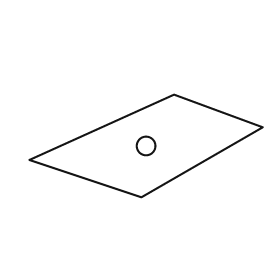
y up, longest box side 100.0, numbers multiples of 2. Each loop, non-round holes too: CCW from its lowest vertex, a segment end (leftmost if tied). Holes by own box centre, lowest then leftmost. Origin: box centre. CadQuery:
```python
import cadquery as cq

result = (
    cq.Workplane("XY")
    .moveTo(-2.0, -22.0)
    .lineTo(50.0, 8.0)
    .lineTo(12.0, 22.0)
    .lineTo(-50.0, -6.0)
    .close()
    .moveTo(0.0, 0.0)
    .circle(4.0)
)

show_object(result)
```